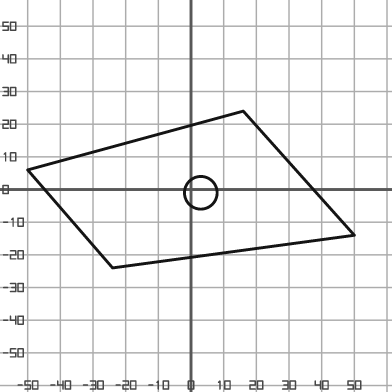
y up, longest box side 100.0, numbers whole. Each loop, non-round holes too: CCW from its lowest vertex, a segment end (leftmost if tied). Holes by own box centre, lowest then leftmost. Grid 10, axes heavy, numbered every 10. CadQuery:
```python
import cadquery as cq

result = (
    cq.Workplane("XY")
    .moveTo(-24.0, -24.0)
    .lineTo(50.0, -14.0)
    .lineTo(16.0, 24.0)
    .lineTo(-50.0, 6.0)
    .close()
    .moveTo(3.0, -1.0)
    .circle(5.0)
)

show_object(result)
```